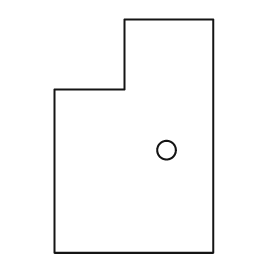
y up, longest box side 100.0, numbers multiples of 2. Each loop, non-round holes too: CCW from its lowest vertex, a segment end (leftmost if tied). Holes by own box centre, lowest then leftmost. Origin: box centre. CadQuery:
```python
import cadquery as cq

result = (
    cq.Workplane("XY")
    .moveTo(-34.0, -50.0)
    .lineTo(34.0, -50.0)
    .lineTo(34.0, 50.0)
    .lineTo(-4.0, 50.0)
    .lineTo(-4.0, 20.0)
    .lineTo(-34.0, 20.0)
    .close()
    .moveTo(14.0, -6.0)
    .circle(4.0)
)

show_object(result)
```